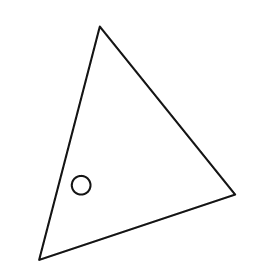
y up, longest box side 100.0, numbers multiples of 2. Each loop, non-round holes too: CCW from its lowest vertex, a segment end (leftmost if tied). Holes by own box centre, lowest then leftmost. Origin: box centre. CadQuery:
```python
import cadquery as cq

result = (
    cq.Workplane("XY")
    .moveTo(-42.0, -50.0)
    .lineTo(42.0, -22.0)
    .lineTo(-16.0, 50.0)
    .close()
    .moveTo(-24.0, -18.0)
    .circle(4.0)
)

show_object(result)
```